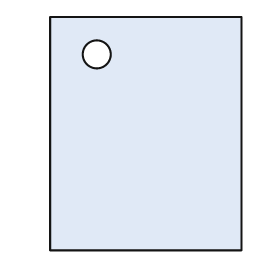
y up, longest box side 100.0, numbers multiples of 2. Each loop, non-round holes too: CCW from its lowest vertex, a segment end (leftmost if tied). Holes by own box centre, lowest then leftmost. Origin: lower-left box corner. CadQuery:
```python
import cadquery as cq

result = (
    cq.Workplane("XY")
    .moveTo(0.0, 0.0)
    .lineTo(82.0, 0.0)
    .lineTo(82.0, 100.0)
    .lineTo(0.0, 100.0)
    .close()
    .moveTo(20.0, 84.0)
    .circle(6.0)
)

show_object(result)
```